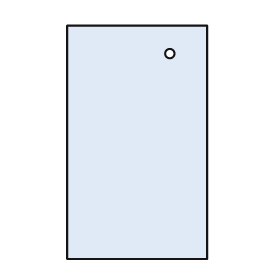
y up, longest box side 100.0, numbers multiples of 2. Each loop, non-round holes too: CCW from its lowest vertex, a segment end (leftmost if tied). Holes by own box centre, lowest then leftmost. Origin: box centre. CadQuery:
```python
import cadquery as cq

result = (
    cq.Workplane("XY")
    .moveTo(-30.0, -50.0)
    .lineTo(30.0, -50.0)
    .lineTo(30.0, 50.0)
    .lineTo(-30.0, 50.0)
    .close()
    .moveTo(14.0, 38.0)
    .circle(2.0)
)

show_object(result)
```